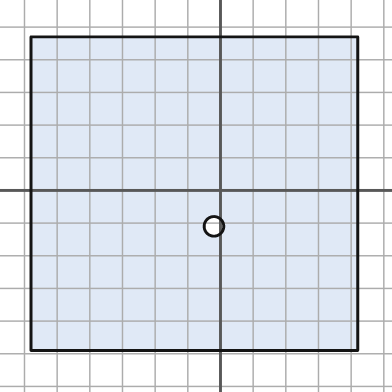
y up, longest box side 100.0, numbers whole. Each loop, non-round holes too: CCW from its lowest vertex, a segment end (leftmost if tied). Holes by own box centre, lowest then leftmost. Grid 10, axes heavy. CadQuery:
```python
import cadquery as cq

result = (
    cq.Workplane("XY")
    .moveTo(-58.0, -49.0)
    .lineTo(42.0, -49.0)
    .lineTo(42.0, 47.0)
    .lineTo(-58.0, 47.0)
    .close()
    .moveTo(-2.0, -11.0)
    .circle(3.0)
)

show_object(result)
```